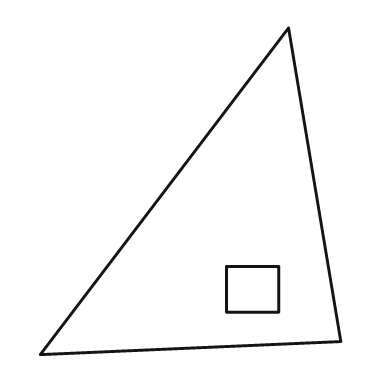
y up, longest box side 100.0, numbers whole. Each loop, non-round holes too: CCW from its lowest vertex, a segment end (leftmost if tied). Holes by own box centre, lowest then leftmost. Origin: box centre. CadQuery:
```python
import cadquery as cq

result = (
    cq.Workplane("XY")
    .moveTo(-46.0, -50.0)
    .lineTo(46.0, -46.0)
    .lineTo(30.0, 50.0)
    .close()
    .moveTo(11.0, -37.0)
    .lineTo(27.0, -37.0)
    .lineTo(27.0, -23.0)
    .lineTo(11.0, -23.0)
    .close()
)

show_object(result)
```